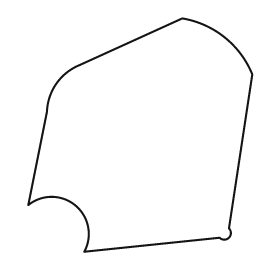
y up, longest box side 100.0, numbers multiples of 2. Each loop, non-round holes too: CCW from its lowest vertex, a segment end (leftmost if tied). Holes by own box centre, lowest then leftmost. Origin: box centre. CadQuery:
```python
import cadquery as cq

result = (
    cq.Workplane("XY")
    .moveTo(-24.0, -50.0)
    .lineTo(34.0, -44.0)
    .threePointArc((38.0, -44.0), (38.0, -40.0))
    .lineTo(48.0, 26.0)
    .threePointArc((36.0, 42.0), (18.0, 50.0))
    .lineTo(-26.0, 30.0)
    .threePointArc((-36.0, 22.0), (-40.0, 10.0))
    .lineTo(-48.0, -30.0)
    .threePointArc((-28.0, -30.0), (-24.0, -50.0))
    .close()
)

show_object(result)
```